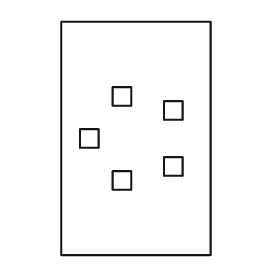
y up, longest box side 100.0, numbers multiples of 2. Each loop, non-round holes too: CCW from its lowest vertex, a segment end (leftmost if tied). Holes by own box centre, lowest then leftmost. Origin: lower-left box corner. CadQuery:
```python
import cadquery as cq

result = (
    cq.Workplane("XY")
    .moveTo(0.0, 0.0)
    .lineTo(64.0, 0.0)
    .lineTo(64.0, 100.0)
    .lineTo(0.0, 100.0)
    .close()
    .moveTo(22.0, 28.0)
    .lineTo(30.0, 28.0)
    .lineTo(30.0, 36.0)
    .lineTo(22.0, 36.0)
    .close()
    .moveTo(44.0, 34.0)
    .lineTo(52.0, 34.0)
    .lineTo(52.0, 42.0)
    .lineTo(44.0, 42.0)
    .close()
    .moveTo(8.0, 46.0)
    .lineTo(16.0, 46.0)
    .lineTo(16.0, 54.0)
    .lineTo(8.0, 54.0)
    .close()
    .moveTo(44.0, 58.0)
    .lineTo(52.0, 58.0)
    .lineTo(52.0, 66.0)
    .lineTo(44.0, 66.0)
    .close()
    .moveTo(22.0, 64.0)
    .lineTo(30.0, 64.0)
    .lineTo(30.0, 72.0)
    .lineTo(22.0, 72.0)
    .close()
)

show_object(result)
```